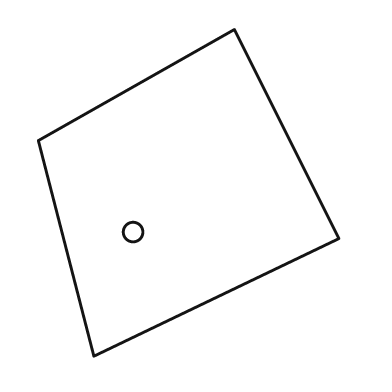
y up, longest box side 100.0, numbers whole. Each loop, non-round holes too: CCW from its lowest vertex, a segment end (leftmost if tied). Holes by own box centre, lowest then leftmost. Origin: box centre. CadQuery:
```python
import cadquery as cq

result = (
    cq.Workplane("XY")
    .moveTo(-29.0, -50.0)
    .lineTo(46.0, -14.0)
    .lineTo(14.0, 50.0)
    .lineTo(-46.0, 16.0)
    .close()
    .moveTo(-17.0, -12.0)
    .circle(3.0)
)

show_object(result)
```